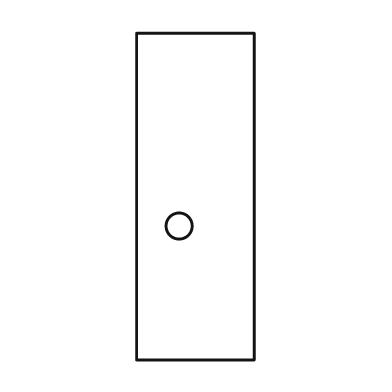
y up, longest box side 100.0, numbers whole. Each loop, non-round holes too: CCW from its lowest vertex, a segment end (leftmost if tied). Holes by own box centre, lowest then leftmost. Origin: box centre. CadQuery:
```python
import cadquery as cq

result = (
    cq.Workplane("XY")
    .moveTo(-18.0, -50.0)
    .lineTo(18.0, -50.0)
    .lineTo(18.0, 50.0)
    .lineTo(-18.0, 50.0)
    .close()
    .moveTo(-5.0, -9.0)
    .circle(4.0)
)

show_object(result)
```